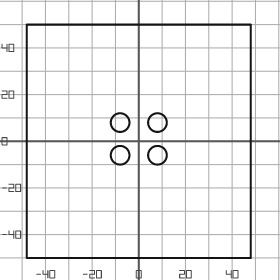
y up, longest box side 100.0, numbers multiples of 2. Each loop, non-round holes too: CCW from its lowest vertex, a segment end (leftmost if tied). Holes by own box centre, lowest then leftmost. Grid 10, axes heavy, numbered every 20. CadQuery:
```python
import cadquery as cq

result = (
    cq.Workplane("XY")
    .moveTo(-48.0, -50.0)
    .lineTo(48.0, -50.0)
    .lineTo(48.0, 50.0)
    .lineTo(-48.0, 50.0)
    .close()
    .moveTo(-8.0, -6.0)
    .circle(4.0)
    .moveTo(8.0, -6.0)
    .circle(4.0)
    .moveTo(-8.0, 8.0)
    .circle(4.0)
    .moveTo(8.0, 8.0)
    .circle(4.0)
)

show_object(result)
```